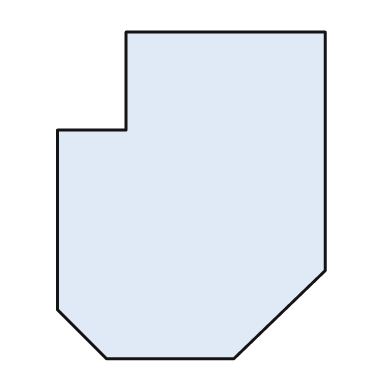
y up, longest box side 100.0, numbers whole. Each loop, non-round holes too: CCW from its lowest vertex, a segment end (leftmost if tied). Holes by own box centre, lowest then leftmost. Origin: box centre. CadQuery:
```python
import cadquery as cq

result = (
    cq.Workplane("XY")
    .moveTo(-26.0, -50.0)
    .lineTo(13.0, -50.0)
    .lineTo(41.0, -23.0)
    .lineTo(41.0, 50.0)
    .lineTo(-20.0, 50.0)
    .lineTo(-20.0, 20.0)
    .lineTo(-41.0, 20.0)
    .lineTo(-41.0, -35.0)
    .close()
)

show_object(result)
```